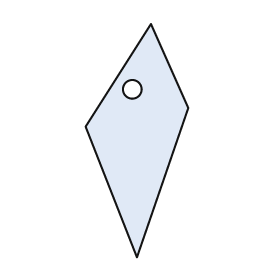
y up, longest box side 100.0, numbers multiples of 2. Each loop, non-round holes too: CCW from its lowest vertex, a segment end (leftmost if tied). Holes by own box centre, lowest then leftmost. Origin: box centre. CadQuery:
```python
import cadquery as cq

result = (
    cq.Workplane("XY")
    .moveTo(0.0, -50.0)
    .lineTo(22.0, 14.0)
    .lineTo(6.0, 50.0)
    .lineTo(-22.0, 6.0)
    .close()
    .moveTo(-2.0, 22.0)
    .circle(4.0)
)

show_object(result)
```